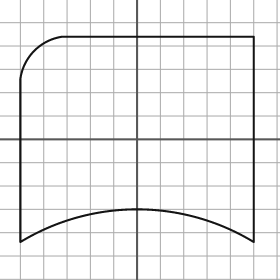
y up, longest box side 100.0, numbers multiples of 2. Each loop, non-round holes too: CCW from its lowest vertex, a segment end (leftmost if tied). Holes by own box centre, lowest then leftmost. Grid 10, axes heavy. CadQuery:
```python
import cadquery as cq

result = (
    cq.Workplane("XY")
    .moveTo(-50.0, -44.0)
    .threePointArc((0.0, -30.0), (50.0, -44.0))
    .lineTo(50.0, 44.0)
    .lineTo(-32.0, 44.0)
    .threePointArc((-44.0, 38.0), (-50.0, 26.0))
    .close()
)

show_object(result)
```